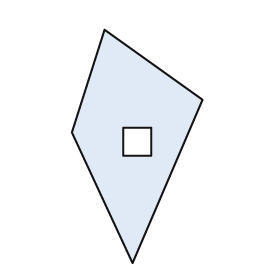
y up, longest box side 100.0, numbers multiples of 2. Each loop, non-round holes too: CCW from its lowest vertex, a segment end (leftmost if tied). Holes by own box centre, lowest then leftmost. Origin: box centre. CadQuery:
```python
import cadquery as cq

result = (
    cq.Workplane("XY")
    .moveTo(-2.0, -50.0)
    .lineTo(28.0, 20.0)
    .lineTo(-14.0, 50.0)
    .lineTo(-28.0, 6.0)
    .close()
    .moveTo(-6.0, -4.0)
    .lineTo(6.0, -4.0)
    .lineTo(6.0, 8.0)
    .lineTo(-6.0, 8.0)
    .close()
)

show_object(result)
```